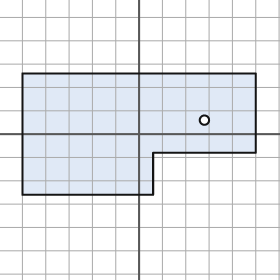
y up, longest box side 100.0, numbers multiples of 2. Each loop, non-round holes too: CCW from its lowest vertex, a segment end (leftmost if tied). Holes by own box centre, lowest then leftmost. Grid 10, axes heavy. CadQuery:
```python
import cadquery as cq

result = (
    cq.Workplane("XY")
    .moveTo(-50.0, -26.0)
    .lineTo(6.0, -26.0)
    .lineTo(6.0, -8.0)
    .lineTo(50.0, -8.0)
    .lineTo(50.0, 26.0)
    .lineTo(-50.0, 26.0)
    .close()
    .moveTo(28.0, 6.0)
    .circle(2.0)
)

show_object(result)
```